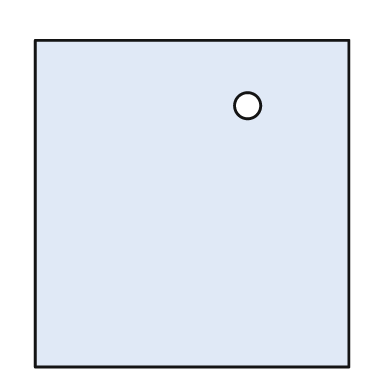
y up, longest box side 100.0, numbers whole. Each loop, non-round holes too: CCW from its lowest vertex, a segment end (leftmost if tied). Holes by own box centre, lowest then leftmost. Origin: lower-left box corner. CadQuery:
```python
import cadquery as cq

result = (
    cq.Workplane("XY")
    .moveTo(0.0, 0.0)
    .lineTo(96.0, 0.0)
    .lineTo(96.0, 100.0)
    .lineTo(0.0, 100.0)
    .close()
    .moveTo(65.0, 80.0)
    .circle(4.0)
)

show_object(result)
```